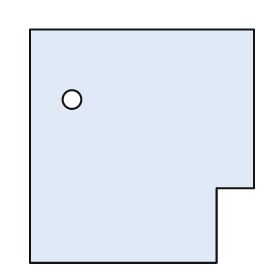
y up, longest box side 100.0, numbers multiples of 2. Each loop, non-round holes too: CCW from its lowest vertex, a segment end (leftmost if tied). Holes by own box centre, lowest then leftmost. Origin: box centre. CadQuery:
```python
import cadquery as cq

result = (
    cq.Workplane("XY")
    .moveTo(-48.0, -50.0)
    .lineTo(32.0, -50.0)
    .lineTo(32.0, -18.0)
    .lineTo(48.0, -18.0)
    .lineTo(48.0, 50.0)
    .lineTo(-48.0, 50.0)
    .close()
    .moveTo(-30.0, 20.0)
    .circle(4.0)
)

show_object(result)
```